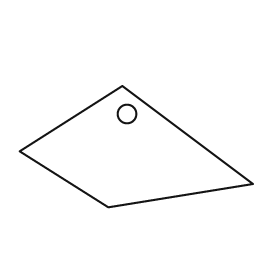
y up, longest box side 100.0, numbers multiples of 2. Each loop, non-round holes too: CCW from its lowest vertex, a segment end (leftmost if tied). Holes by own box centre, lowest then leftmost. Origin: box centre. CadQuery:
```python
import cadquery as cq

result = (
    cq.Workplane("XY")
    .moveTo(-12.0, -26.0)
    .lineTo(50.0, -16.0)
    .lineTo(-6.0, 26.0)
    .lineTo(-50.0, -2.0)
    .close()
    .moveTo(-4.0, 14.0)
    .circle(4.0)
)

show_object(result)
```